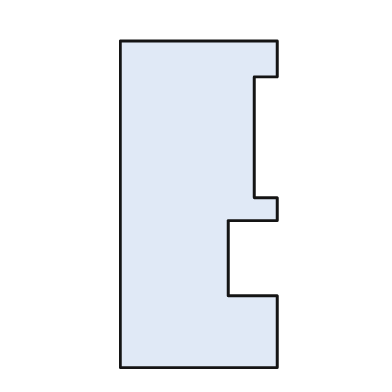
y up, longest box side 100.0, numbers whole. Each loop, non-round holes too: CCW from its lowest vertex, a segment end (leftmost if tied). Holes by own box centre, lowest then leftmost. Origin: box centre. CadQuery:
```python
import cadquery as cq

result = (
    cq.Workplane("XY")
    .moveTo(-24.0, -50.0)
    .lineTo(24.0, -50.0)
    .lineTo(24.0, -28.0)
    .lineTo(9.0, -28.0)
    .lineTo(9.0, -5.0)
    .lineTo(24.0, -5.0)
    .lineTo(24.0, 2.0)
    .lineTo(17.0, 2.0)
    .lineTo(17.0, 39.0)
    .lineTo(24.0, 39.0)
    .lineTo(24.0, 50.0)
    .lineTo(-24.0, 50.0)
    .close()
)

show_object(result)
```